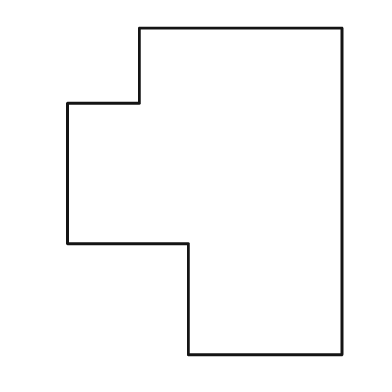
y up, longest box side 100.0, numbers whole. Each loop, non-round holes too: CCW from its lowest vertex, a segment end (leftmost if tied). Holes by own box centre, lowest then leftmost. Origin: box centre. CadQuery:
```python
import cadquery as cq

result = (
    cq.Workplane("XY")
    .moveTo(-5.0, -50.0)
    .lineTo(42.0, -50.0)
    .lineTo(42.0, 50.0)
    .lineTo(-20.0, 50.0)
    .lineTo(-20.0, 27.0)
    .lineTo(-42.0, 27.0)
    .lineTo(-42.0, -16.0)
    .lineTo(-5.0, -16.0)
    .close()
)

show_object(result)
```